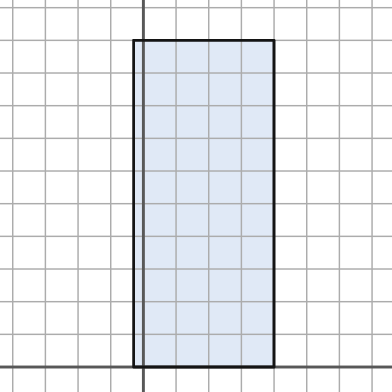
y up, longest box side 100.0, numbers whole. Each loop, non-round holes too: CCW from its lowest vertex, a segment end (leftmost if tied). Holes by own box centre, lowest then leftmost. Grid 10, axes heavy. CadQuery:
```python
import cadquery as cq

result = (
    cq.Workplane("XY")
    .moveTo(-3.0, 0.0)
    .lineTo(40.0, 0.0)
    .lineTo(40.0, 100.0)
    .lineTo(-3.0, 100.0)
    .close()
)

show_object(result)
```